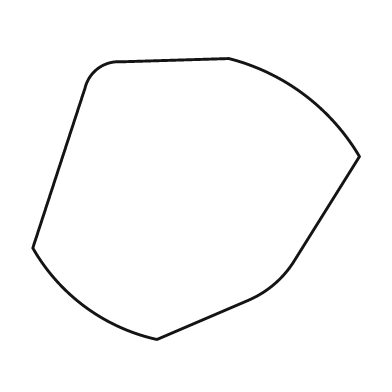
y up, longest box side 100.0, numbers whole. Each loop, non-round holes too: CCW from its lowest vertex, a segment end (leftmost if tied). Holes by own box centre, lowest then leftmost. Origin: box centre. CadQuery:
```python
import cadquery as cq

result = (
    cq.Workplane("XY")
    .moveTo(-12.0, -43.0)
    .lineTo(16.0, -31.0)
    .threePointArc((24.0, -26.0), (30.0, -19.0))
    .lineTo(50.0, 13.0)
    .threePointArc((33.0, 32.0), (10.0, 43.0))
    .lineTo(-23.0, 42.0)
    .threePointArc((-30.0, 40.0), (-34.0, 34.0))
    .lineTo(-50.0, -15.0)
    .threePointArc((-34.0, -33.0), (-12.0, -43.0))
    .close()
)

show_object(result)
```